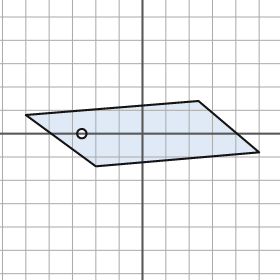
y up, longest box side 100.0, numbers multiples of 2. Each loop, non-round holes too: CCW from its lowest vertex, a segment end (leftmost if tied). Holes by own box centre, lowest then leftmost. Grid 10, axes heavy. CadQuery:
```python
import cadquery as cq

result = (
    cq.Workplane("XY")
    .moveTo(-20.0, -14.0)
    .lineTo(50.0, -8.0)
    .lineTo(24.0, 14.0)
    .lineTo(-50.0, 8.0)
    .close()
    .moveTo(-26.0, 0.0)
    .circle(2.0)
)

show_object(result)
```